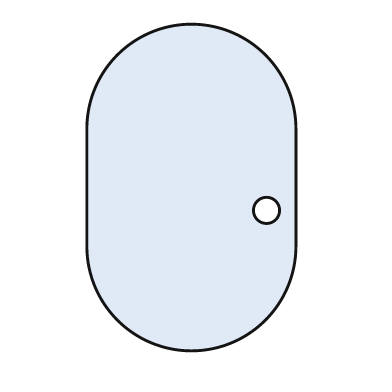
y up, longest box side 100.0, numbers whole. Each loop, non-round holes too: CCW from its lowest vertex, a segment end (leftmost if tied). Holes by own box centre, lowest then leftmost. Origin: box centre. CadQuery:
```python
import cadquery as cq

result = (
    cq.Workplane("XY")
    .moveTo(-32.0, -18.0)
    .threePointArc((0.0, -50.0), (32.0, -18.0))
    .lineTo(32.0, 18.0)
    .threePointArc((0.0, 50.0), (-32.0, 18.0))
    .close()
    .moveTo(23.0, -7.0)
    .circle(4.0)
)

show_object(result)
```